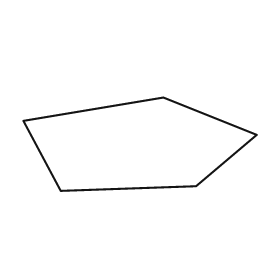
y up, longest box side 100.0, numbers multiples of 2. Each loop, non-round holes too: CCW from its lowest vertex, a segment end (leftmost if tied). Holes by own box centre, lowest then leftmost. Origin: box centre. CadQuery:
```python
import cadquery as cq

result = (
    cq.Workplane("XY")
    .moveTo(-34.0, -20.0)
    .lineTo(24.0, -18.0)
    .lineTo(50.0, 4.0)
    .lineTo(10.0, 20.0)
    .lineTo(-50.0, 10.0)
    .close()
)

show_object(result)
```